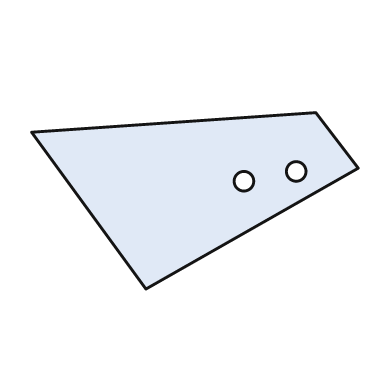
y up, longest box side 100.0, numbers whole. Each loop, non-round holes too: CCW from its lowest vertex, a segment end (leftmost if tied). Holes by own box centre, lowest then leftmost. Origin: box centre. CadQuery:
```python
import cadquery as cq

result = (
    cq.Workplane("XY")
    .moveTo(-15.0, -27.0)
    .lineTo(50.0, 10.0)
    .lineTo(37.0, 27.0)
    .lineTo(-50.0, 21.0)
    .close()
    .moveTo(15.0, 6.0)
    .circle(3.0)
    .moveTo(31.0, 9.0)
    .circle(3.0)
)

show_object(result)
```